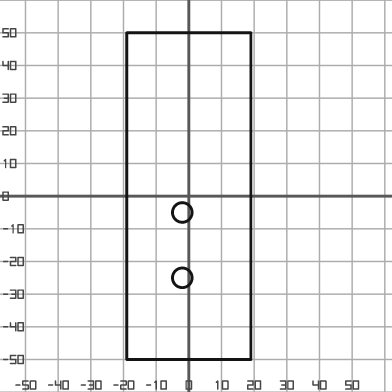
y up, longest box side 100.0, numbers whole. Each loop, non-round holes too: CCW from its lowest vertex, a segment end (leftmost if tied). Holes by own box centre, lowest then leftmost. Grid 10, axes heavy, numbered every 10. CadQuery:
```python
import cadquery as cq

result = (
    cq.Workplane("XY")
    .moveTo(-19.0, -50.0)
    .lineTo(19.0, -50.0)
    .lineTo(19.0, 50.0)
    .lineTo(-19.0, 50.0)
    .close()
    .moveTo(-2.0, -25.0)
    .circle(3.0)
    .moveTo(-2.0, -5.0)
    .circle(3.0)
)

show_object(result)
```